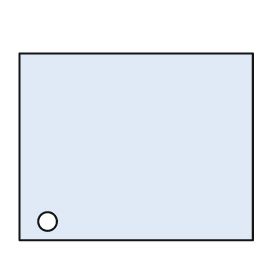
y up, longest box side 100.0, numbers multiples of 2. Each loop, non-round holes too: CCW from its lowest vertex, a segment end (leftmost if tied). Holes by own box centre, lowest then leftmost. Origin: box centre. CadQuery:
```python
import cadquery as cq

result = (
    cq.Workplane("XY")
    .moveTo(-50.0, -40.0)
    .lineTo(50.0, -40.0)
    .lineTo(50.0, 40.0)
    .lineTo(-50.0, 40.0)
    .close()
    .moveTo(-38.0, -32.0)
    .circle(4.0)
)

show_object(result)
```